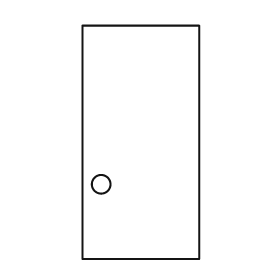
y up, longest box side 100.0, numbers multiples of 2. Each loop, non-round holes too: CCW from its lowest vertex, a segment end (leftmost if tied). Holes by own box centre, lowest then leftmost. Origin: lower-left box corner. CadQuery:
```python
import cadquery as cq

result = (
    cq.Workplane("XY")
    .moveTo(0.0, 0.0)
    .lineTo(50.0, 0.0)
    .lineTo(50.0, 100.0)
    .lineTo(0.0, 100.0)
    .close()
    .moveTo(8.0, 32.0)
    .circle(4.0)
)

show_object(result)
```